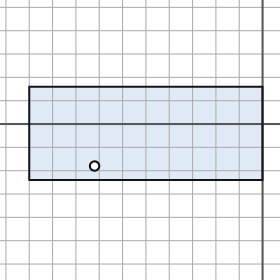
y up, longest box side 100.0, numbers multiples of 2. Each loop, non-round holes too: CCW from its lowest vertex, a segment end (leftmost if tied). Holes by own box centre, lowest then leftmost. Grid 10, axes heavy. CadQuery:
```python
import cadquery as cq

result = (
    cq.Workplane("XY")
    .moveTo(-100.0, -24.0)
    .lineTo(0.0, -24.0)
    .lineTo(0.0, 16.0)
    .lineTo(-100.0, 16.0)
    .close()
    .moveTo(-72.0, -18.0)
    .circle(2.0)
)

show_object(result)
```